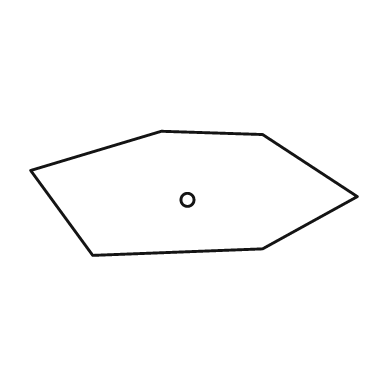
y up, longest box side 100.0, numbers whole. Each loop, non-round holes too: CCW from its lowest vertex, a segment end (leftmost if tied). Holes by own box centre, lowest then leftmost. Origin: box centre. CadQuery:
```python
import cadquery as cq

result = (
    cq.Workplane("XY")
    .moveTo(-31.0, -19.0)
    .lineTo(21.0, -17.0)
    .lineTo(50.0, -1.0)
    .lineTo(21.0, 18.0)
    .lineTo(-10.0, 19.0)
    .lineTo(-50.0, 7.0)
    .close()
    .moveTo(-2.0, -2.0)
    .circle(2.0)
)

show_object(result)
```